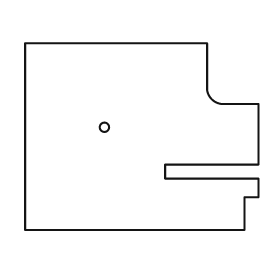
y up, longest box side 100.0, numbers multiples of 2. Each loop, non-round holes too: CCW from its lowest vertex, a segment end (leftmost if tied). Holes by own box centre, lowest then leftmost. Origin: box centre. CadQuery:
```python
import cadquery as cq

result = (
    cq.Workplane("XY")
    .moveTo(-50.0, -40.0)
    .lineTo(44.0, -40.0)
    .lineTo(44.0, -26.0)
    .lineTo(50.0, -26.0)
    .lineTo(50.0, -18.0)
    .lineTo(10.0, -18.0)
    .lineTo(10.0, -12.0)
    .lineTo(50.0, -12.0)
    .lineTo(50.0, 14.0)
    .lineTo(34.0, 14.0)
    .threePointArc((30.0, 16.0), (28.0, 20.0))
    .lineTo(28.0, 40.0)
    .lineTo(-50.0, 40.0)
    .close()
    .moveTo(-16.0, 4.0)
    .circle(2.0)
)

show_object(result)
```